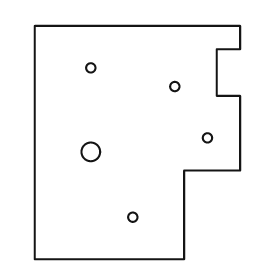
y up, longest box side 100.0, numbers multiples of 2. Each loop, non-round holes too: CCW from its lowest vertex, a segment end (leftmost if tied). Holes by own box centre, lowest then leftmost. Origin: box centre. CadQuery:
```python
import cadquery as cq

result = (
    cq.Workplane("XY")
    .moveTo(-44.0, -50.0)
    .lineTo(20.0, -50.0)
    .lineTo(20.0, -12.0)
    .lineTo(44.0, -12.0)
    .lineTo(44.0, 20.0)
    .lineTo(34.0, 20.0)
    .lineTo(34.0, 40.0)
    .lineTo(44.0, 40.0)
    .lineTo(44.0, 50.0)
    .lineTo(-44.0, 50.0)
    .close()
    .moveTo(-2.0, -32.0)
    .circle(2.0)
    .moveTo(-20.0, -4.0)
    .circle(4.0)
    .moveTo(30.0, 2.0)
    .circle(2.0)
    .moveTo(16.0, 24.0)
    .circle(2.0)
    .moveTo(-20.0, 32.0)
    .circle(2.0)
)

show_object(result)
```